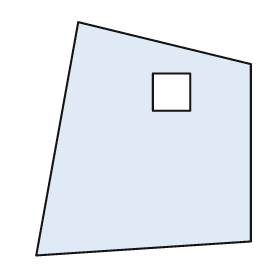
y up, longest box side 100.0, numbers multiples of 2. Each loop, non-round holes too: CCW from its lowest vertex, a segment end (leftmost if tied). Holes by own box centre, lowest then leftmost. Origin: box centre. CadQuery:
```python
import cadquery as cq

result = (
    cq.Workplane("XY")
    .moveTo(-46.0, -50.0)
    .lineTo(46.0, -44.0)
    .lineTo(46.0, 32.0)
    .lineTo(-28.0, 50.0)
    .close()
    .moveTo(4.0, 12.0)
    .lineTo(20.0, 12.0)
    .lineTo(20.0, 28.0)
    .lineTo(4.0, 28.0)
    .close()
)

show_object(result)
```